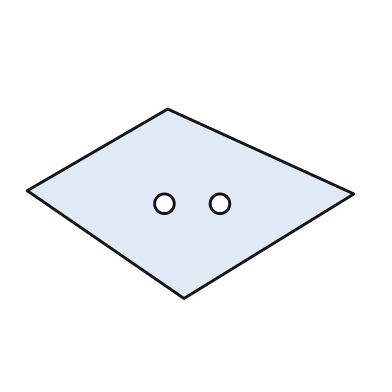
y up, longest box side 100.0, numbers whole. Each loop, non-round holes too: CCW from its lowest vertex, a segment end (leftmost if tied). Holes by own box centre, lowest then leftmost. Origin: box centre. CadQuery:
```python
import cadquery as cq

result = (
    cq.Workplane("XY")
    .moveTo(-2.0, -29.0)
    .lineTo(50.0, 3.0)
    .lineTo(-7.0, 29.0)
    .lineTo(-50.0, 4.0)
    .close()
    .moveTo(-8.0, 0.0)
    .circle(3.0)
    .moveTo(9.0, 0.0)
    .circle(3.0)
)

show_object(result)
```